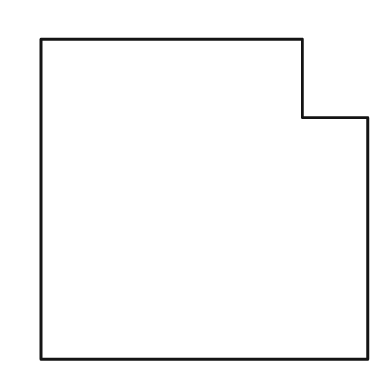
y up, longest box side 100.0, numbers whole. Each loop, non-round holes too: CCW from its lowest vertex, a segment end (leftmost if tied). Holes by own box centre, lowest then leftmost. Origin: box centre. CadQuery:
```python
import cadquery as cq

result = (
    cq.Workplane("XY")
    .moveTo(-50.0, -49.0)
    .lineTo(50.0, -49.0)
    .lineTo(50.0, 25.0)
    .lineTo(30.0, 25.0)
    .lineTo(30.0, 49.0)
    .lineTo(-50.0, 49.0)
    .close()
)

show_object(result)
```